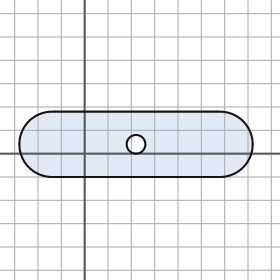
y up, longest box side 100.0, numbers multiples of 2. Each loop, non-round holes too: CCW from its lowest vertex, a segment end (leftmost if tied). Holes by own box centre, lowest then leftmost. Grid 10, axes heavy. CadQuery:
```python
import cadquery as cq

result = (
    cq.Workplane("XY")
    .moveTo(-14.0, -10.0)
    .lineTo(58.0, -10.0)
    .threePointArc((72.0, 4.0), (58.0, 18.0))
    .lineTo(-14.0, 18.0)
    .threePointArc((-28.0, 4.0), (-14.0, -10.0))
    .close()
    .moveTo(22.0, 4.0)
    .circle(4.0)
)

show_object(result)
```